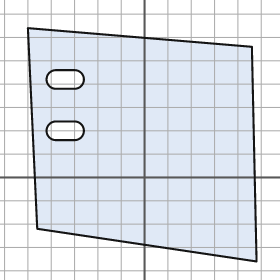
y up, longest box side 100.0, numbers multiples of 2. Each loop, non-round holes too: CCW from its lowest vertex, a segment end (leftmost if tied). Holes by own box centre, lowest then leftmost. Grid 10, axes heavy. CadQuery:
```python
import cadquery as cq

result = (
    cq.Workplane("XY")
    .moveTo(48.0, -36.0)
    .lineTo(46.0, 56.0)
    .lineTo(-50.0, 64.0)
    .lineTo(-46.0, -22.0)
    .close()
    .moveTo(-38.0, 16.0)
    .lineTo(-30.0, 16.0)
    .threePointArc((-26.0, 20.0), (-30.0, 24.0))
    .lineTo(-38.0, 24.0)
    .threePointArc((-42.0, 20.0), (-38.0, 16.0))
    .close()
    .moveTo(-38.0, 38.0)
    .lineTo(-30.0, 38.0)
    .threePointArc((-26.0, 42.0), (-30.0, 46.0))
    .lineTo(-38.0, 46.0)
    .threePointArc((-42.0, 42.0), (-38.0, 38.0))
    .close()
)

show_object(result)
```